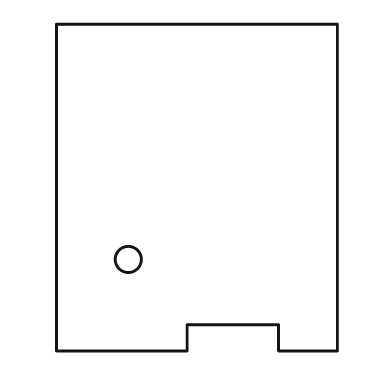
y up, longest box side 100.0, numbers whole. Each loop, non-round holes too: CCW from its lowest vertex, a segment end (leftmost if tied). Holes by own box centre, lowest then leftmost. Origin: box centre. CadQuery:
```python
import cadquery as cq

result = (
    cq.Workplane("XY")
    .moveTo(-43.0, -50.0)
    .lineTo(-3.0, -50.0)
    .lineTo(-3.0, -42.0)
    .lineTo(25.0, -42.0)
    .lineTo(25.0, -50.0)
    .lineTo(43.0, -50.0)
    .lineTo(43.0, 50.0)
    .lineTo(-43.0, 50.0)
    .close()
    .moveTo(-21.0, -22.0)
    .circle(4.0)
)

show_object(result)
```